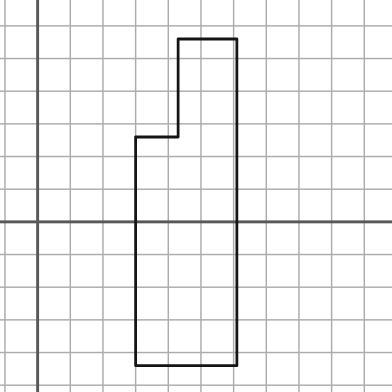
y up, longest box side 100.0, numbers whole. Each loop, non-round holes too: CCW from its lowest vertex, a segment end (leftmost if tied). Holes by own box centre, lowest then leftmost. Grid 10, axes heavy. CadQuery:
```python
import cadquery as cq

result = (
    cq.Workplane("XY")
    .moveTo(30.0, -44.0)
    .lineTo(61.0, -44.0)
    .lineTo(61.0, 56.0)
    .lineTo(43.0, 56.0)
    .lineTo(43.0, 26.0)
    .lineTo(30.0, 26.0)
    .close()
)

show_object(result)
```